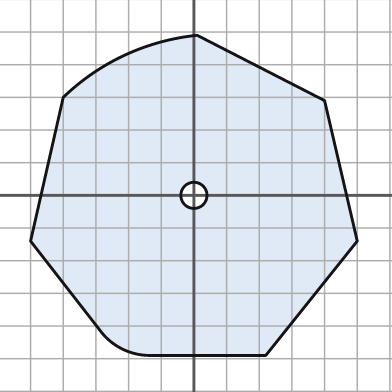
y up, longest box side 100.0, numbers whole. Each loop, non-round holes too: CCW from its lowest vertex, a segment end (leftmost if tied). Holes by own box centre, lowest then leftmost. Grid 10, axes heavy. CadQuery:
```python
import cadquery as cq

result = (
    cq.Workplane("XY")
    .moveTo(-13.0, -49.0)
    .lineTo(22.0, -49.0)
    .lineTo(50.0, -14.0)
    .lineTo(40.0, 29.0)
    .lineTo(1.0, 49.0)
    .threePointArc((-21.0, 43.0), (-40.0, 30.0))
    .lineTo(-50.0, -14.0)
    .lineTo(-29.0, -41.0)
    .threePointArc((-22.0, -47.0), (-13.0, -49.0))
    .close()
    .moveTo(0.0, 0.0)
    .circle(4.0)
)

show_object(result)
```